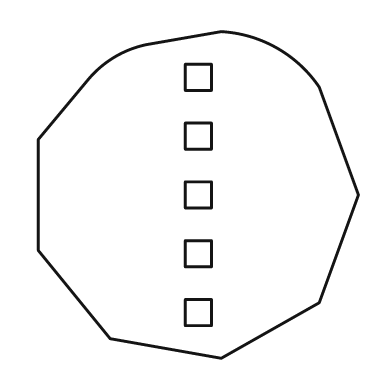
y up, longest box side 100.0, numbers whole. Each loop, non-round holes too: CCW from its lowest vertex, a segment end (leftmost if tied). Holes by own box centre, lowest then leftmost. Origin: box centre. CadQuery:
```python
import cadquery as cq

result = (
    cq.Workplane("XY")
    .moveTo(7.0, -50.0)
    .lineTo(37.0, -33.0)
    .lineTo(49.0, 0.0)
    .lineTo(37.0, 33.0)
    .threePointArc((24.0, 45.0), (7.0, 50.0))
    .lineTo(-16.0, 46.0)
    .threePointArc((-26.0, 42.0), (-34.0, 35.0))
    .lineTo(-49.0, 17.0)
    .lineTo(-49.0, -17.0)
    .lineTo(-27.0, -44.0)
    .close()
    .moveTo(-4.0, -40.0)
    .lineTo(4.0, -40.0)
    .lineTo(4.0, -32.0)
    .lineTo(-4.0, -32.0)
    .close()
    .moveTo(-4.0, -22.0)
    .lineTo(4.0, -22.0)
    .lineTo(4.0, -14.0)
    .lineTo(-4.0, -14.0)
    .close()
    .moveTo(-4.0, -4.0)
    .lineTo(4.0, -4.0)
    .lineTo(4.0, 4.0)
    .lineTo(-4.0, 4.0)
    .close()
    .moveTo(-4.0, 14.0)
    .lineTo(4.0, 14.0)
    .lineTo(4.0, 22.0)
    .lineTo(-4.0, 22.0)
    .close()
    .moveTo(-4.0, 32.0)
    .lineTo(4.0, 32.0)
    .lineTo(4.0, 40.0)
    .lineTo(-4.0, 40.0)
    .close()
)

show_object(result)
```